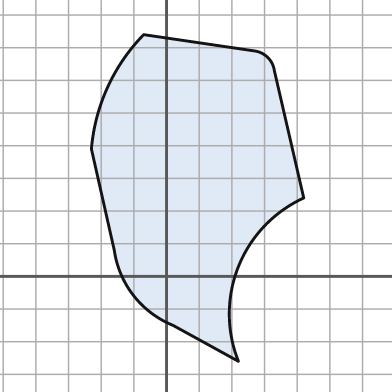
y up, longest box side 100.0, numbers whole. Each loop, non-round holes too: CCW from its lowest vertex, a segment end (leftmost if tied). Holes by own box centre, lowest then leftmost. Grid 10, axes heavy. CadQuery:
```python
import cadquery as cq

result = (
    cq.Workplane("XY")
    .moveTo(22.0, -26.0)
    .threePointArc((22.0, 3.0), (42.0, 24.0))
    .lineTo(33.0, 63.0)
    .threePointArc((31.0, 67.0), (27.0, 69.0))
    .lineTo(-7.0, 74.0)
    .threePointArc((-18.0, 58.0), (-23.0, 39.0))
    .lineTo(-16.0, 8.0)
    .threePointArc((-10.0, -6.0), (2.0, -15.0))
    .close()
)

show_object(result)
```